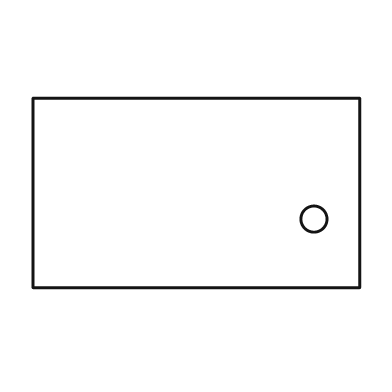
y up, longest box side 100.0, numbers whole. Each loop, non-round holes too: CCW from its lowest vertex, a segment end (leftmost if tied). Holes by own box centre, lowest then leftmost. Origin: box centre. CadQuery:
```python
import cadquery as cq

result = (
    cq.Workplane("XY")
    .moveTo(-50.0, -29.0)
    .lineTo(50.0, -29.0)
    .lineTo(50.0, 29.0)
    .lineTo(-50.0, 29.0)
    .close()
    .moveTo(36.0, -8.0)
    .circle(4.0)
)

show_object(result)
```